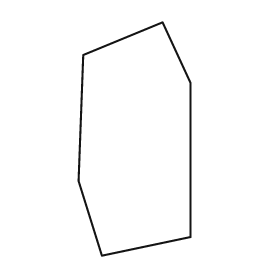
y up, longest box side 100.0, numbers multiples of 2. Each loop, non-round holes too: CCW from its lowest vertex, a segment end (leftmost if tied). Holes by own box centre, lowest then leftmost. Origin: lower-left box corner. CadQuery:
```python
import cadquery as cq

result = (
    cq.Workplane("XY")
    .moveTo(10.0, 0.0)
    .lineTo(48.0, 8.0)
    .lineTo(48.0, 74.0)
    .lineTo(36.0, 100.0)
    .lineTo(2.0, 86.0)
    .lineTo(0.0, 32.0)
    .close()
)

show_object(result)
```